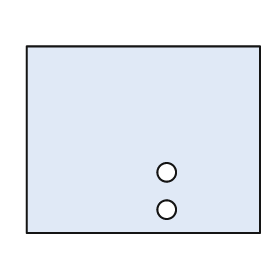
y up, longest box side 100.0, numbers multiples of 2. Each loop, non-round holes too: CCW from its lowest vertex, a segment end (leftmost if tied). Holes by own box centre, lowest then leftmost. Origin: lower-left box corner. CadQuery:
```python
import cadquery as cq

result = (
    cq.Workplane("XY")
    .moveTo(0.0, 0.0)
    .lineTo(100.0, 0.0)
    .lineTo(100.0, 80.0)
    .lineTo(0.0, 80.0)
    .close()
    .moveTo(60.0, 10.0)
    .circle(4.0)
    .moveTo(60.0, 26.0)
    .circle(4.0)
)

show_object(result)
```